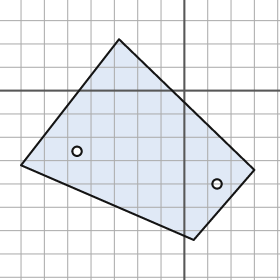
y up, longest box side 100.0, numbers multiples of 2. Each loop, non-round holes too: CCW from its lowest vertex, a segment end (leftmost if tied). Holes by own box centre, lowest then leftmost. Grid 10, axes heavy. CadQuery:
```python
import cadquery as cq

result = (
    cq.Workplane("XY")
    .moveTo(4.0, -64.0)
    .lineTo(30.0, -34.0)
    .lineTo(-28.0, 22.0)
    .lineTo(-70.0, -32.0)
    .close()
    .moveTo(14.0, -40.0)
    .circle(2.0)
    .moveTo(-46.0, -26.0)
    .circle(2.0)
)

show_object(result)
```